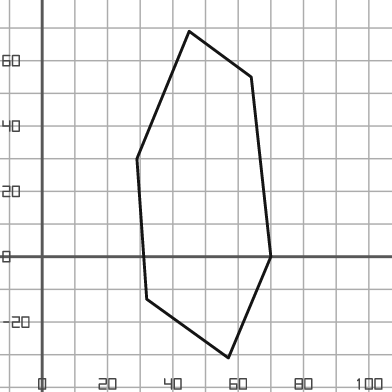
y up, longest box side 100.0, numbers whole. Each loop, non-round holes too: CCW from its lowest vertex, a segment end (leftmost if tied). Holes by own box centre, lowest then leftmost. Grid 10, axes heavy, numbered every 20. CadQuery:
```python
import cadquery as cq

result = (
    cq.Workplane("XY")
    .moveTo(57.0, -31.0)
    .lineTo(70.0, 0.0)
    .lineTo(64.0, 55.0)
    .lineTo(45.0, 69.0)
    .lineTo(29.0, 30.0)
    .lineTo(32.0, -13.0)
    .close()
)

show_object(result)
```